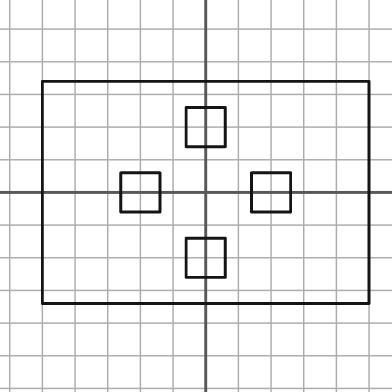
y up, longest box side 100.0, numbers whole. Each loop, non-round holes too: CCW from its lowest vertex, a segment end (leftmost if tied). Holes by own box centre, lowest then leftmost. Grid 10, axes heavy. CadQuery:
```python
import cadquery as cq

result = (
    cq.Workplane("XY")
    .moveTo(-50.0, -34.0)
    .lineTo(50.0, -34.0)
    .lineTo(50.0, 34.0)
    .lineTo(-50.0, 34.0)
    .close()
    .moveTo(-6.0, -26.0)
    .lineTo(6.0, -26.0)
    .lineTo(6.0, -14.0)
    .lineTo(-6.0, -14.0)
    .close()
    .moveTo(-26.0, -6.0)
    .lineTo(-14.0, -6.0)
    .lineTo(-14.0, 6.0)
    .lineTo(-26.0, 6.0)
    .close()
    .moveTo(14.0, -6.0)
    .lineTo(26.0, -6.0)
    .lineTo(26.0, 6.0)
    .lineTo(14.0, 6.0)
    .close()
    .moveTo(-6.0, 14.0)
    .lineTo(6.0, 14.0)
    .lineTo(6.0, 26.0)
    .lineTo(-6.0, 26.0)
    .close()
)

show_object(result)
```